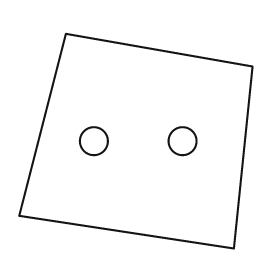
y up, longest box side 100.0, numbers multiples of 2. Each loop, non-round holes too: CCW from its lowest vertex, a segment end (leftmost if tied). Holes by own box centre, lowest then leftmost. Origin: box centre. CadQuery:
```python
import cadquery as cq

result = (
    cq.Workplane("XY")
    .moveTo(42.0, -46.0)
    .lineTo(50.0, 32.0)
    .lineTo(-30.0, 46.0)
    .lineTo(-50.0, -32.0)
    .close()
    .moveTo(-18.0, 0.0)
    .circle(6.0)
    .moveTo(20.0, 0.0)
    .circle(6.0)
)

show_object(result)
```